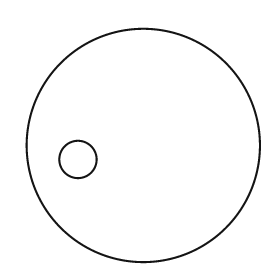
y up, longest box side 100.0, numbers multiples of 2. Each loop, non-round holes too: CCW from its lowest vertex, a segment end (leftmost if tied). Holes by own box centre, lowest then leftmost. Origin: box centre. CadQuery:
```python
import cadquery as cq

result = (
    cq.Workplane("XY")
    .moveTo(0.0, 0.0)
    .circle(50.0)
    .moveTo(-28.0, -6.0)
    .circle(8.0)
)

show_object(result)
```